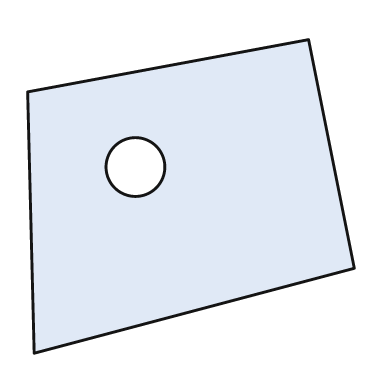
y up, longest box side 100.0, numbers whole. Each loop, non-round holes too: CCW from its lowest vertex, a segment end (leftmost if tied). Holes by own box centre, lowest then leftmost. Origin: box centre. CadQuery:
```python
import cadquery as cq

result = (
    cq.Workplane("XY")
    .moveTo(-48.0, -48.0)
    .lineTo(50.0, -22.0)
    .lineTo(36.0, 48.0)
    .lineTo(-50.0, 32.0)
    .close()
    .moveTo(-17.0, 9.0)
    .circle(9.0)
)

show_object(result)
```